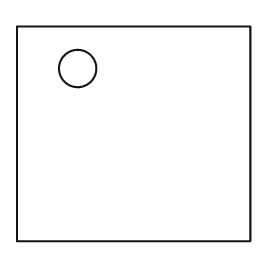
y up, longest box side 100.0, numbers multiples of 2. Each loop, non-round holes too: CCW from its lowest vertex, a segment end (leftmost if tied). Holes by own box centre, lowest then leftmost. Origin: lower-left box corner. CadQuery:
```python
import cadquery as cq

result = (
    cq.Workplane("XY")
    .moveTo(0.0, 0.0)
    .lineTo(100.0, 0.0)
    .lineTo(100.0, 92.0)
    .lineTo(0.0, 92.0)
    .close()
    .moveTo(26.0, 74.0)
    .circle(8.0)
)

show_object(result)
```